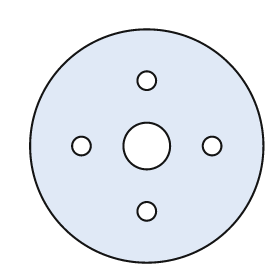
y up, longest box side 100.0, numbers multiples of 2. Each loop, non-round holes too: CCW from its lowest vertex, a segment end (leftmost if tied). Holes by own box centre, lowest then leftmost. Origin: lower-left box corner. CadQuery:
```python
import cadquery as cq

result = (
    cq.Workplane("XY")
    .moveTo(50.0, 50.0)
    .circle(50.0)
    .moveTo(50.0, 22.0)
    .circle(4.0)
    .moveTo(22.0, 50.0)
    .circle(4.0)
    .moveTo(50.0, 50.0)
    .circle(10.0)
    .moveTo(78.0, 50.0)
    .circle(4.0)
    .moveTo(50.0, 78.0)
    .circle(4.0)
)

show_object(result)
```